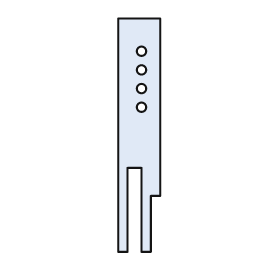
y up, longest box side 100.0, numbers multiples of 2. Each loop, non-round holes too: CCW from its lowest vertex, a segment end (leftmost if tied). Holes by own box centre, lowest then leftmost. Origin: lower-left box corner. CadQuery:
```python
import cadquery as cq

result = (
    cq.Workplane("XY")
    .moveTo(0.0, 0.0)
    .lineTo(4.0, 0.0)
    .lineTo(4.0, 36.0)
    .lineTo(10.0, 36.0)
    .lineTo(10.0, 0.0)
    .lineTo(14.0, 0.0)
    .lineTo(14.0, 24.0)
    .lineTo(18.0, 24.0)
    .lineTo(18.0, 100.0)
    .lineTo(0.0, 100.0)
    .close()
    .moveTo(10.0, 62.0)
    .circle(2.0)
    .moveTo(10.0, 70.0)
    .circle(2.0)
    .moveTo(10.0, 78.0)
    .circle(2.0)
    .moveTo(10.0, 86.0)
    .circle(2.0)
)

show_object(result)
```